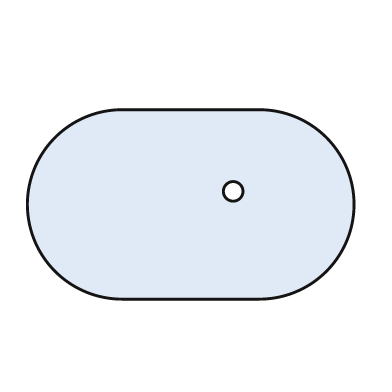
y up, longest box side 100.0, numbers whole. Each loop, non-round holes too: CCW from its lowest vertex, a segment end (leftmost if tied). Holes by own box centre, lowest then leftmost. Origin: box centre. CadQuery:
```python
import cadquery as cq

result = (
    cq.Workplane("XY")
    .moveTo(-21.0, -29.0)
    .lineTo(21.0, -29.0)
    .threePointArc((50.0, 0.0), (21.0, 29.0))
    .lineTo(-21.0, 29.0)
    .threePointArc((-50.0, 0.0), (-21.0, -29.0))
    .close()
    .moveTo(13.0, 4.0)
    .circle(3.0)
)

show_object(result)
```